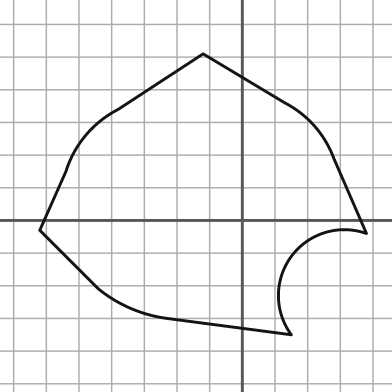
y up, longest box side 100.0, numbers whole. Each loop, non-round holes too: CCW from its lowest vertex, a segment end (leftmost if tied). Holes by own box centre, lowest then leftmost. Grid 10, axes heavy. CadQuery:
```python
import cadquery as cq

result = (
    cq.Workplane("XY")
    .moveTo(15.0, -35.0)
    .threePointArc((15.0, -11.0), (38.0, -4.0))
    .lineTo(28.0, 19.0)
    .threePointArc((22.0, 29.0), (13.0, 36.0))
    .lineTo(-12.0, 51.0)
    .lineTo(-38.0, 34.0)
    .threePointArc((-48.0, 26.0), (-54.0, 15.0))
    .lineTo(-62.0, -3.0)
    .lineTo(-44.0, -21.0)
    .threePointArc((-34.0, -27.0), (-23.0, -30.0))
    .close()
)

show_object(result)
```